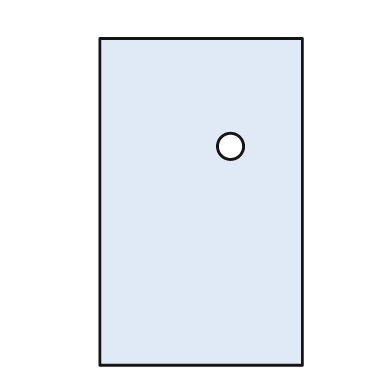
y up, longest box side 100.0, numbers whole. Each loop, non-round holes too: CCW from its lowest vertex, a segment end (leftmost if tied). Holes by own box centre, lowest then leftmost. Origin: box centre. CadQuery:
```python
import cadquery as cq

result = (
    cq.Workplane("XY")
    .moveTo(-31.0, -50.0)
    .lineTo(31.0, -50.0)
    .lineTo(31.0, 50.0)
    .lineTo(-31.0, 50.0)
    .close()
    .moveTo(9.0, 17.0)
    .circle(4.0)
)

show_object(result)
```